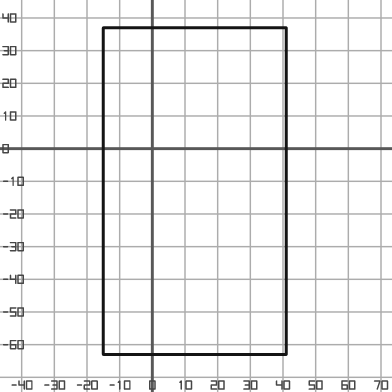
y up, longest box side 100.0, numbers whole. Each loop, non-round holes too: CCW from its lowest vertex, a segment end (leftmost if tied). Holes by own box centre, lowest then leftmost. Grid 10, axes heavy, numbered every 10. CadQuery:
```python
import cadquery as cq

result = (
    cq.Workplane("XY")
    .moveTo(-15.0, -63.0)
    .lineTo(41.0, -63.0)
    .lineTo(41.0, 37.0)
    .lineTo(-15.0, 37.0)
    .close()
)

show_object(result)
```